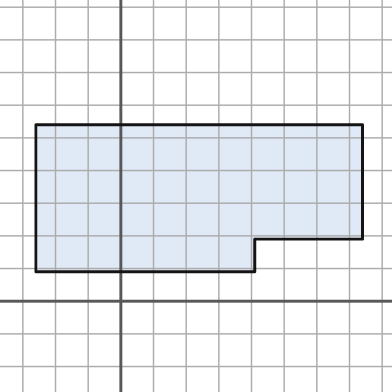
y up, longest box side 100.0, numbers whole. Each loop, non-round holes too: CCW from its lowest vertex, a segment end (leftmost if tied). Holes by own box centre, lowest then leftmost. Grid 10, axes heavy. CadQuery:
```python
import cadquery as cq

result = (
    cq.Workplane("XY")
    .moveTo(-26.0, 9.0)
    .lineTo(41.0, 9.0)
    .lineTo(41.0, 19.0)
    .lineTo(74.0, 19.0)
    .lineTo(74.0, 54.0)
    .lineTo(-26.0, 54.0)
    .close()
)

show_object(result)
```